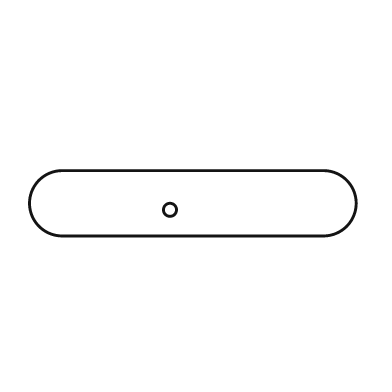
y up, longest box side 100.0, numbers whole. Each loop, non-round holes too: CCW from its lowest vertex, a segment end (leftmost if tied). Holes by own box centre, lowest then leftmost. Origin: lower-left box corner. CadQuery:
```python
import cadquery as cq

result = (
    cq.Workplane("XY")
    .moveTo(10.0, 0.0)
    .lineTo(90.0, 0.0)
    .threePointArc((100.0, 10.0), (90.0, 20.0))
    .lineTo(10.0, 20.0)
    .threePointArc((0.0, 10.0), (10.0, 0.0))
    .close()
    .moveTo(43.0, 8.0)
    .circle(2.0)
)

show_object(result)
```